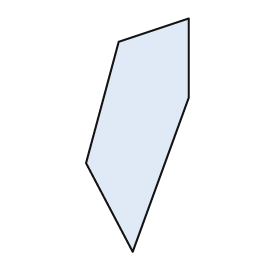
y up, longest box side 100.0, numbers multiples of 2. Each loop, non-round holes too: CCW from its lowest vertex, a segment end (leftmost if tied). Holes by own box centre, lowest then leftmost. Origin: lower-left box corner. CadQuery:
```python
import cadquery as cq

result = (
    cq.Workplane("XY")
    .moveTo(20.0, 0.0)
    .lineTo(44.0, 66.0)
    .lineTo(44.0, 100.0)
    .lineTo(14.0, 90.0)
    .lineTo(0.0, 38.0)
    .close()
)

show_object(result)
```